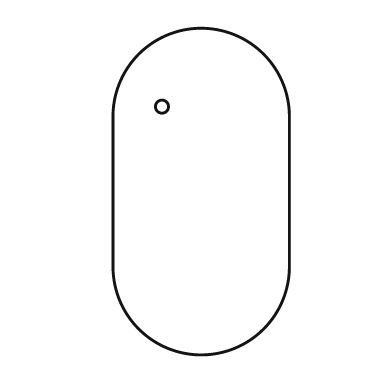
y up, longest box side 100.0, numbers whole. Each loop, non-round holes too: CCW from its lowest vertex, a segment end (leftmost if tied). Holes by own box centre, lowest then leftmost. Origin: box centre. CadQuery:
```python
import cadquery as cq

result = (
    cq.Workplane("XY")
    .moveTo(-27.0, -23.0)
    .threePointArc((0.0, -50.0), (27.0, -23.0))
    .lineTo(27.0, 23.0)
    .threePointArc((0.0, 50.0), (-27.0, 23.0))
    .close()
    .moveTo(-12.0, 26.0)
    .circle(2.0)
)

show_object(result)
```